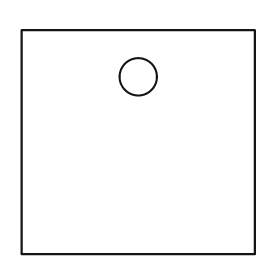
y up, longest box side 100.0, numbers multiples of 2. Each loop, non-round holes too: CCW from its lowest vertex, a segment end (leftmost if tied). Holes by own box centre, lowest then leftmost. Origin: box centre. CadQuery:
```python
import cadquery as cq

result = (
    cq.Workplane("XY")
    .moveTo(-50.0, -48.0)
    .lineTo(50.0, -48.0)
    .lineTo(50.0, 48.0)
    .lineTo(-50.0, 48.0)
    .close()
    .moveTo(0.0, 28.0)
    .circle(8.0)
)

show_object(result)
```